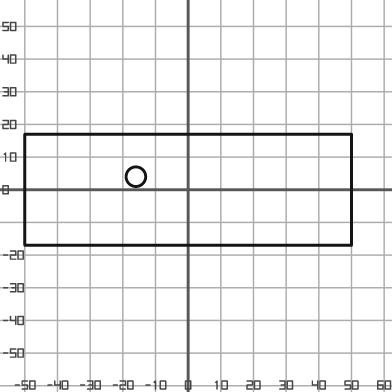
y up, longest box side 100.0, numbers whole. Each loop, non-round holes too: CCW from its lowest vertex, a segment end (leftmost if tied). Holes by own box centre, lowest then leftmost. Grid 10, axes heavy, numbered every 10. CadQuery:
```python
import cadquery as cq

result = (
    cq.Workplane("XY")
    .moveTo(-50.0, -17.0)
    .lineTo(50.0, -17.0)
    .lineTo(50.0, 17.0)
    .lineTo(-50.0, 17.0)
    .close()
    .moveTo(-16.0, 4.0)
    .circle(3.0)
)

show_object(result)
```